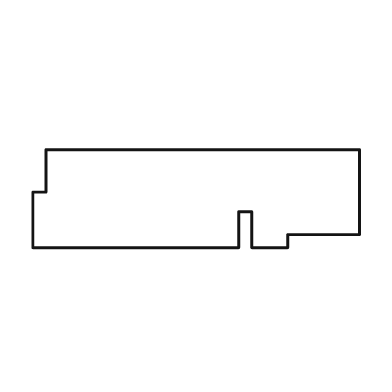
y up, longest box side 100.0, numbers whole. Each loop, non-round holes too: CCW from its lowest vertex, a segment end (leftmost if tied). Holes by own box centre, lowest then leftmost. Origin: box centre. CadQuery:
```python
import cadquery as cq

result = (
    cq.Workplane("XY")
    .moveTo(-50.0, -15.0)
    .lineTo(13.0, -15.0)
    .lineTo(13.0, -4.0)
    .lineTo(17.0, -4.0)
    .lineTo(17.0, -15.0)
    .lineTo(28.0, -15.0)
    .lineTo(28.0, -11.0)
    .lineTo(50.0, -11.0)
    .lineTo(50.0, 15.0)
    .lineTo(-46.0, 15.0)
    .lineTo(-46.0, 2.0)
    .lineTo(-50.0, 2.0)
    .close()
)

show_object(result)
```